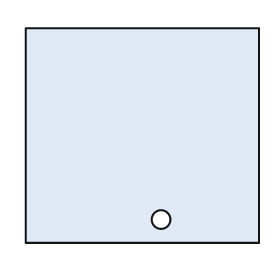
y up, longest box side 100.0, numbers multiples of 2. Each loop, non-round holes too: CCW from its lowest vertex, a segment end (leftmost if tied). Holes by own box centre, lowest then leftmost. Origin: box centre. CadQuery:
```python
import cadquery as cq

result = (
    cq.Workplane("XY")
    .moveTo(-50.0, -46.0)
    .lineTo(50.0, -46.0)
    .lineTo(50.0, 46.0)
    .lineTo(-50.0, 46.0)
    .close()
    .moveTo(8.0, -36.0)
    .circle(4.0)
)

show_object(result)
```